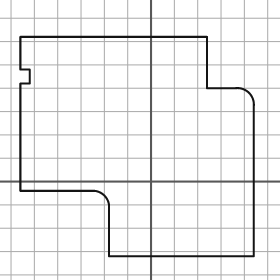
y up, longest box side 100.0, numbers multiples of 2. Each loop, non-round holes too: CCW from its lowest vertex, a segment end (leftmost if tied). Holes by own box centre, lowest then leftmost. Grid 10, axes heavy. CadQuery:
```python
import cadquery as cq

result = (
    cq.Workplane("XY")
    .moveTo(-18.0, -32.0)
    .lineTo(44.0, -32.0)
    .lineTo(44.0, 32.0)
    .threePointArc((42.0, 38.0), (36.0, 40.0))
    .lineTo(24.0, 40.0)
    .lineTo(24.0, 62.0)
    .lineTo(-56.0, 62.0)
    .lineTo(-56.0, 48.0)
    .lineTo(-52.0, 48.0)
    .lineTo(-52.0, 42.0)
    .lineTo(-56.0, 42.0)
    .lineTo(-56.0, -4.0)
    .lineTo(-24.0, -4.0)
    .threePointArc((-20.0, -6.0), (-18.0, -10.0))
    .close()
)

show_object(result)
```